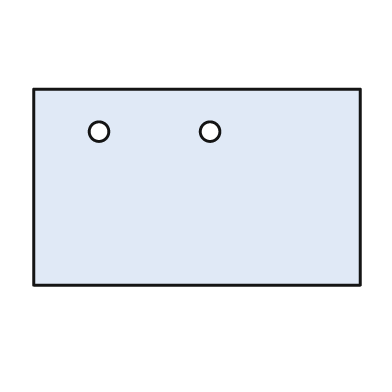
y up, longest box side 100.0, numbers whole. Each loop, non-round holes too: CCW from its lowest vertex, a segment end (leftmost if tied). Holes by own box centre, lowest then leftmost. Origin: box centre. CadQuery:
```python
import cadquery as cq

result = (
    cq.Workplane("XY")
    .moveTo(-50.0, -30.0)
    .lineTo(50.0, -30.0)
    .lineTo(50.0, 30.0)
    .lineTo(-50.0, 30.0)
    .close()
    .moveTo(-30.0, 17.0)
    .circle(3.0)
    .moveTo(4.0, 17.0)
    .circle(3.0)
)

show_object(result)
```